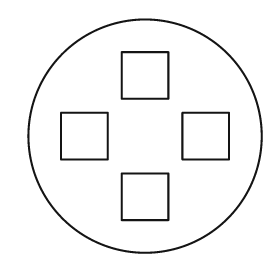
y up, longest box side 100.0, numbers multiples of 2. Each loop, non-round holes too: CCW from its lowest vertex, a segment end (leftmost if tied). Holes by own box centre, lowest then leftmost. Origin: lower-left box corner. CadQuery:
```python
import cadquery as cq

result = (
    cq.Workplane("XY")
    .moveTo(50.0, 50.0)
    .circle(50.0)
    .moveTo(40.0, 14.0)
    .lineTo(60.0, 14.0)
    .lineTo(60.0, 34.0)
    .lineTo(40.0, 34.0)
    .close()
    .moveTo(14.0, 40.0)
    .lineTo(34.0, 40.0)
    .lineTo(34.0, 60.0)
    .lineTo(14.0, 60.0)
    .close()
    .moveTo(66.0, 40.0)
    .lineTo(86.0, 40.0)
    .lineTo(86.0, 60.0)
    .lineTo(66.0, 60.0)
    .close()
    .moveTo(40.0, 66.0)
    .lineTo(60.0, 66.0)
    .lineTo(60.0, 86.0)
    .lineTo(40.0, 86.0)
    .close()
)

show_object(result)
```